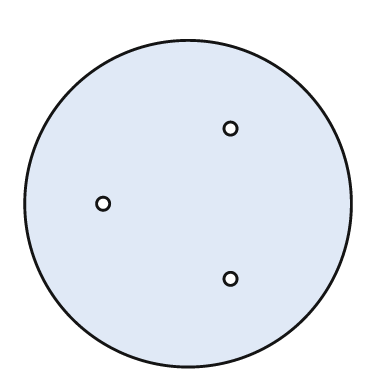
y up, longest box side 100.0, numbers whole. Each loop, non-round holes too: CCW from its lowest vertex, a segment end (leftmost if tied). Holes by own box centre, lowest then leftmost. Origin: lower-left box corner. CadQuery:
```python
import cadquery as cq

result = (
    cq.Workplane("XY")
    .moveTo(50.0, 50.0)
    .circle(50.0)
    .moveTo(63.0, 27.0)
    .circle(2.0)
    .moveTo(24.0, 50.0)
    .circle(2.0)
    .moveTo(63.0, 73.0)
    .circle(2.0)
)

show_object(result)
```